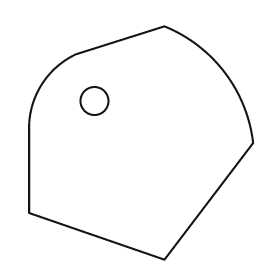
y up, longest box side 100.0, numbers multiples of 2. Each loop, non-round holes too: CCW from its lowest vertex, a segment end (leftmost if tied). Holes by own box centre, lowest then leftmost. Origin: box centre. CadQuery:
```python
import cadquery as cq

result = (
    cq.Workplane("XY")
    .moveTo(10.0, -50.0)
    .lineTo(48.0, 0.0)
    .threePointArc((36.0, 30.0), (10.0, 50.0))
    .lineTo(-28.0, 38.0)
    .threePointArc((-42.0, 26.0), (-48.0, 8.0))
    .lineTo(-48.0, -30.0)
    .close()
    .moveTo(-20.0, 18.0)
    .circle(6.0)
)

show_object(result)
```